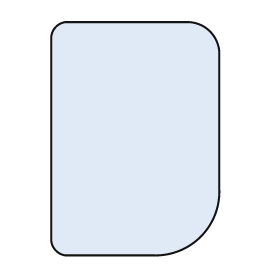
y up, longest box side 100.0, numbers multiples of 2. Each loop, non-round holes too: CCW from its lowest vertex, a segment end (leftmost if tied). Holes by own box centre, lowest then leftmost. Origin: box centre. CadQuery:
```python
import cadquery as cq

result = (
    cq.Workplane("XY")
    .moveTo(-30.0, -50.0)
    .lineTo(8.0, -50.0)
    .threePointArc((28.0, -42.0), (36.0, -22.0))
    .lineTo(36.0, 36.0)
    .threePointArc((32.0, 46.0), (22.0, 50.0))
    .lineTo(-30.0, 50.0)
    .threePointArc((-34.0, 48.0), (-36.0, 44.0))
    .lineTo(-36.0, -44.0)
    .threePointArc((-34.0, -48.0), (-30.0, -50.0))
    .close()
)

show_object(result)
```